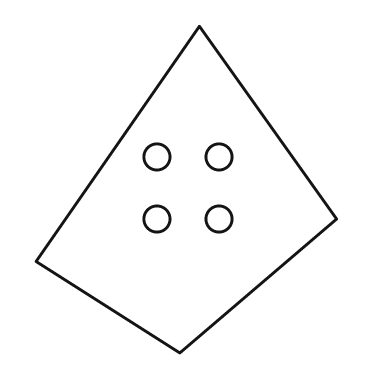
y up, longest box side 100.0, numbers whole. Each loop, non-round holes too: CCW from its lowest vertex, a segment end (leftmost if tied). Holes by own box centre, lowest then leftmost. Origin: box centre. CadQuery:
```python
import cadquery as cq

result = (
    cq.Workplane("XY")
    .moveTo(-2.0, -50.0)
    .lineTo(46.0, -9.0)
    .lineTo(4.0, 50.0)
    .lineTo(-46.0, -22.0)
    .close()
    .moveTo(-9.0, -9.0)
    .circle(4.0)
    .moveTo(10.0, -9.0)
    .circle(4.0)
    .moveTo(-9.0, 10.0)
    .circle(4.0)
    .moveTo(10.0, 10.0)
    .circle(4.0)
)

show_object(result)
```